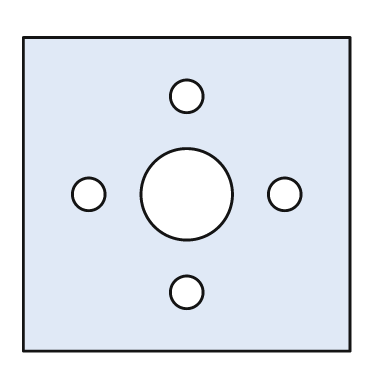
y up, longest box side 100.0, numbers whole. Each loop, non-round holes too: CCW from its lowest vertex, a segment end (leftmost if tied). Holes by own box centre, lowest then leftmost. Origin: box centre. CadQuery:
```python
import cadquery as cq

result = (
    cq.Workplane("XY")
    .moveTo(-50.0, -48.0)
    .lineTo(50.0, -48.0)
    .lineTo(50.0, 48.0)
    .lineTo(-50.0, 48.0)
    .close()
    .moveTo(0.0, -30.0)
    .circle(5.0)
    .moveTo(-30.0, 0.0)
    .circle(5.0)
    .moveTo(0.0, 0.0)
    .circle(14.0)
    .moveTo(30.0, 0.0)
    .circle(5.0)
    .moveTo(0.0, 30.0)
    .circle(5.0)
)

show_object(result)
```